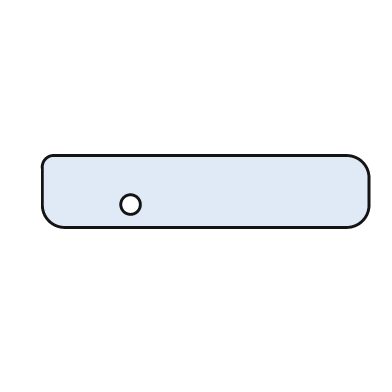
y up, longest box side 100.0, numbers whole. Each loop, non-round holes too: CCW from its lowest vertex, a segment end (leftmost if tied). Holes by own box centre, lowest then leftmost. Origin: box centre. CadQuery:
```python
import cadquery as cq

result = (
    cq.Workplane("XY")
    .moveTo(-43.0, -11.0)
    .lineTo(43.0, -11.0)
    .threePointArc((48.0, -9.0), (50.0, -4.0))
    .lineTo(50.0, 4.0)
    .threePointArc((48.0, 9.0), (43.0, 11.0))
    .lineTo(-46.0, 11.0)
    .threePointArc((-49.0, 10.0), (-50.0, 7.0))
    .lineTo(-50.0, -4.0)
    .threePointArc((-48.0, -9.0), (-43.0, -11.0))
    .close()
    .moveTo(-23.0, -4.0)
    .circle(3.0)
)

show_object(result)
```